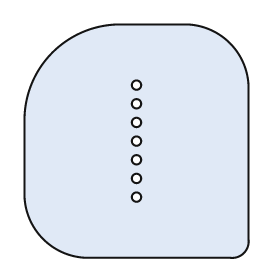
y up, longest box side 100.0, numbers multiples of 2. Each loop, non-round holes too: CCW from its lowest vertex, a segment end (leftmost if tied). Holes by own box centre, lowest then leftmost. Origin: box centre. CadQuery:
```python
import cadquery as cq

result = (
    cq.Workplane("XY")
    .moveTo(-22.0, -50.0)
    .lineTo(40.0, -50.0)
    .threePointArc((46.0, -48.0), (48.0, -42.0))
    .lineTo(48.0, 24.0)
    .threePointArc((40.0, 42.0), (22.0, 50.0))
    .lineTo(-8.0, 50.0)
    .threePointArc((-36.0, 38.0), (-48.0, 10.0))
    .lineTo(-48.0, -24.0)
    .threePointArc((-40.0, -42.0), (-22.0, -50.0))
    .close()
    .moveTo(0.0, -24.0)
    .circle(2.0)
    .moveTo(0.0, -16.0)
    .circle(2.0)
    .moveTo(0.0, -8.0)
    .circle(2.0)
    .moveTo(0.0, 0.0)
    .circle(2.0)
    .moveTo(0.0, 8.0)
    .circle(2.0)
    .moveTo(0.0, 16.0)
    .circle(2.0)
    .moveTo(0.0, 24.0)
    .circle(2.0)
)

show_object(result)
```